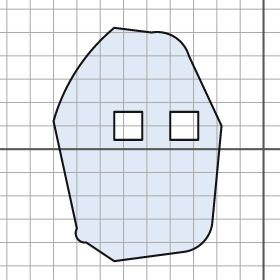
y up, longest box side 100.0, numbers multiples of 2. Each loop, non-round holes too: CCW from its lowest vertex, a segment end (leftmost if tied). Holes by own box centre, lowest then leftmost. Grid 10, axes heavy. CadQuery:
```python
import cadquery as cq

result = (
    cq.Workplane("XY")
    .moveTo(-64.0, -48.0)
    .lineTo(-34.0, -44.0)
    .threePointArc((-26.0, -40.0), (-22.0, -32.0))
    .lineTo(-18.0, 10.0)
    .lineTo(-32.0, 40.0)
    .threePointArc((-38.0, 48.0), (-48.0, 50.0))
    .lineTo(-64.0, 52.0)
    .threePointArc((-80.0, 34.0), (-90.0, 12.0))
    .lineTo(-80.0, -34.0)
    .threePointArc((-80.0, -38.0), (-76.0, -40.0))
    .close()
    .moveTo(-64.0, 4.0)
    .lineTo(-52.0, 4.0)
    .lineTo(-52.0, 16.0)
    .lineTo(-64.0, 16.0)
    .close()
    .moveTo(-40.0, 4.0)
    .lineTo(-28.0, 4.0)
    .lineTo(-28.0, 16.0)
    .lineTo(-40.0, 16.0)
    .close()
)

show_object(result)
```